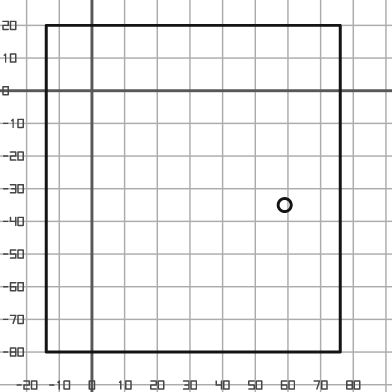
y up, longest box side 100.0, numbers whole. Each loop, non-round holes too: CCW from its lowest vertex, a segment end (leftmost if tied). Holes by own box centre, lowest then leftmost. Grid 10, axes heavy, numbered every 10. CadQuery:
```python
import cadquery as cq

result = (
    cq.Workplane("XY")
    .moveTo(-14.0, -80.0)
    .lineTo(76.0, -80.0)
    .lineTo(76.0, 20.0)
    .lineTo(-14.0, 20.0)
    .close()
    .moveTo(59.0, -35.0)
    .circle(2.0)
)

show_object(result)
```